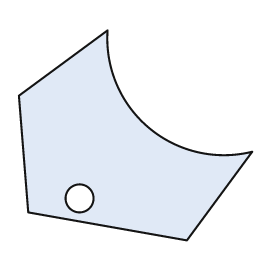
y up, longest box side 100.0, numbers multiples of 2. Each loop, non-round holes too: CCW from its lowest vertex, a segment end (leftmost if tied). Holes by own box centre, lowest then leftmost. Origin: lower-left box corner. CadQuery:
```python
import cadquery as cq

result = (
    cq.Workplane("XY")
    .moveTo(72.0, 0.0)
    .lineTo(100.0, 38.0)
    .threePointArc((56.0, 48.0), (38.0, 90.0))
    .lineTo(0.0, 62.0)
    .lineTo(4.0, 12.0)
    .close()
    .moveTo(26.0, 18.0)
    .circle(6.0)
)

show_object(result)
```